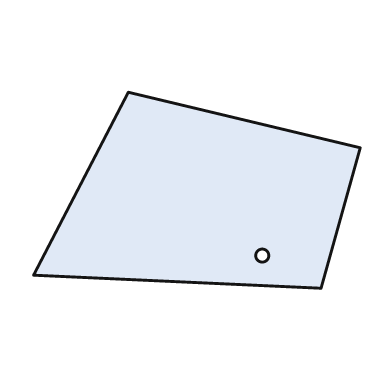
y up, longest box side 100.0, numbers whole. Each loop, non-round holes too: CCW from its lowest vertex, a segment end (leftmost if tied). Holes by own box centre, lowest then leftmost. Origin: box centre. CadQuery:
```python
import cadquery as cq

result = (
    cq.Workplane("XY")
    .moveTo(38.0, -30.0)
    .lineTo(50.0, 13.0)
    .lineTo(-21.0, 30.0)
    .lineTo(-50.0, -26.0)
    .close()
    .moveTo(20.0, -20.0)
    .circle(2.0)
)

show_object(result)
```